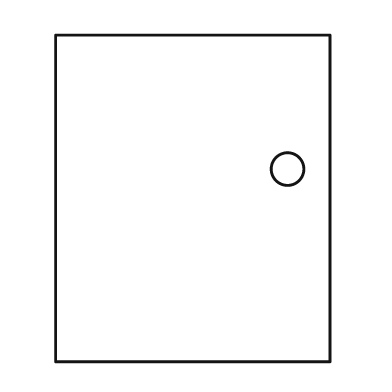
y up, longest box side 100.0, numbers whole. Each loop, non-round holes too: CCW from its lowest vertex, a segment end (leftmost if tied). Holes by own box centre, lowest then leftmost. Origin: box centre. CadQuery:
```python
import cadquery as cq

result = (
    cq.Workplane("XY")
    .moveTo(-42.0, -50.0)
    .lineTo(42.0, -50.0)
    .lineTo(42.0, 50.0)
    .lineTo(-42.0, 50.0)
    .close()
    .moveTo(29.0, 9.0)
    .circle(5.0)
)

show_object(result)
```